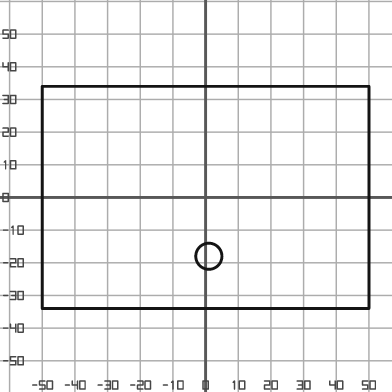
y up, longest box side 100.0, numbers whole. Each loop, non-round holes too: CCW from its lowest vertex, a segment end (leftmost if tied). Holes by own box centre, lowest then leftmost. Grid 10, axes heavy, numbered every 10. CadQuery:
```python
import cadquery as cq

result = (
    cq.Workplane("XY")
    .moveTo(-50.0, -34.0)
    .lineTo(50.0, -34.0)
    .lineTo(50.0, 34.0)
    .lineTo(-50.0, 34.0)
    .close()
    .moveTo(1.0, -18.0)
    .circle(4.0)
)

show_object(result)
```